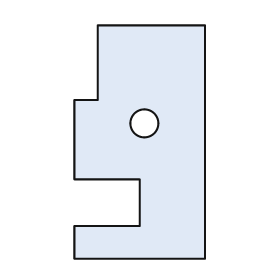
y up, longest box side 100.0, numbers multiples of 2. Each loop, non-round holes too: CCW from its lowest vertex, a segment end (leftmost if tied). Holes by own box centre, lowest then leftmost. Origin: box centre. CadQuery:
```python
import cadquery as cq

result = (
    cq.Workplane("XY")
    .moveTo(-28.0, -50.0)
    .lineTo(28.0, -50.0)
    .lineTo(28.0, 50.0)
    .lineTo(-18.0, 50.0)
    .lineTo(-18.0, 18.0)
    .lineTo(-28.0, 18.0)
    .lineTo(-28.0, -16.0)
    .lineTo(0.0, -16.0)
    .lineTo(0.0, -36.0)
    .lineTo(-28.0, -36.0)
    .close()
    .moveTo(2.0, 8.0)
    .circle(6.0)
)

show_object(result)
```